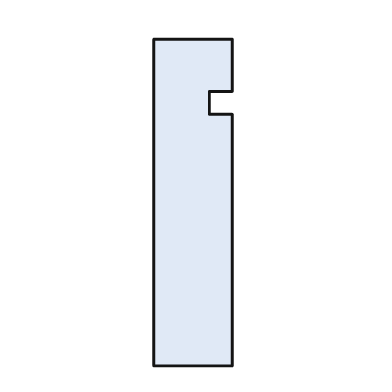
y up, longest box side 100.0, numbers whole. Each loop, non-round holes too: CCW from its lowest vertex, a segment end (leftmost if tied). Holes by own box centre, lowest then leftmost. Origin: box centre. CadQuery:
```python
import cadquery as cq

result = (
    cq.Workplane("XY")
    .moveTo(-12.0, -50.0)
    .lineTo(12.0, -50.0)
    .lineTo(12.0, 27.0)
    .lineTo(5.0, 27.0)
    .lineTo(5.0, 34.0)
    .lineTo(12.0, 34.0)
    .lineTo(12.0, 50.0)
    .lineTo(-12.0, 50.0)
    .close()
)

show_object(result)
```